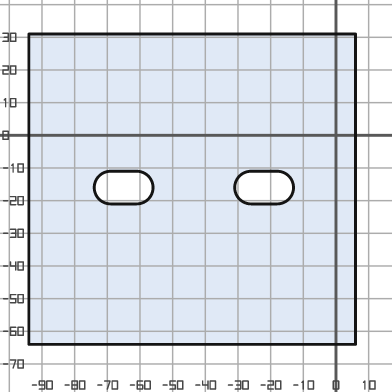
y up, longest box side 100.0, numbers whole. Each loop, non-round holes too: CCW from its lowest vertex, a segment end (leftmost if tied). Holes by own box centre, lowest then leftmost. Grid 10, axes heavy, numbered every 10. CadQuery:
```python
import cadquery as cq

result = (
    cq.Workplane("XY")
    .moveTo(-94.0, -64.0)
    .lineTo(6.0, -64.0)
    .lineTo(6.0, 31.0)
    .lineTo(-94.0, 31.0)
    .close()
    .moveTo(-69.0, -21.0)
    .lineTo(-61.0, -21.0)
    .threePointArc((-56.0, -16.0), (-61.0, -11.0))
    .lineTo(-69.0, -11.0)
    .threePointArc((-74.0, -16.0), (-69.0, -21.0))
    .close()
    .moveTo(-26.0, -21.0)
    .lineTo(-18.0, -21.0)
    .threePointArc((-13.0, -16.0), (-18.0, -11.0))
    .lineTo(-26.0, -11.0)
    .threePointArc((-31.0, -16.0), (-26.0, -21.0))
    .close()
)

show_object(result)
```